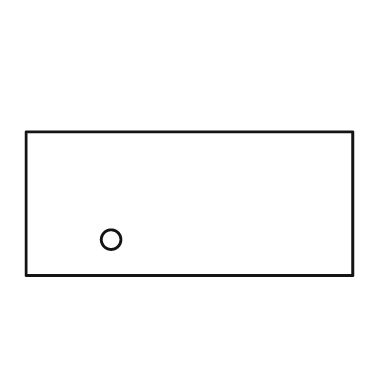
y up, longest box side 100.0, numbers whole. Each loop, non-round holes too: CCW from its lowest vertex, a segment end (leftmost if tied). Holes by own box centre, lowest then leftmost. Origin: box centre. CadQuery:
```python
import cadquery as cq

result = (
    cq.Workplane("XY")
    .moveTo(-50.0, -22.0)
    .lineTo(50.0, -22.0)
    .lineTo(50.0, 22.0)
    .lineTo(-50.0, 22.0)
    .close()
    .moveTo(-24.0, -11.0)
    .circle(3.0)
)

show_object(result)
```